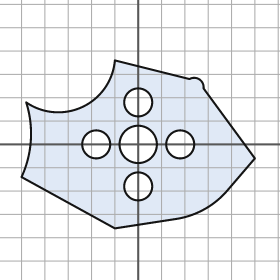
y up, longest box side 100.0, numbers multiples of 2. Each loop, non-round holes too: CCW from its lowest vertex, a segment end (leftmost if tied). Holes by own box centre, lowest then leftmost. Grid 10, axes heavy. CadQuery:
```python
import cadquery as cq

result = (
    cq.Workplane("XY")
    .moveTo(-10.0, -36.0)
    .lineTo(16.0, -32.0)
    .threePointArc((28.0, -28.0), (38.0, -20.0))
    .lineTo(50.0, -6.0)
    .lineTo(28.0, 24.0)
    .threePointArc((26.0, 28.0), (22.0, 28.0))
    .lineTo(-10.0, 36.0)
    .threePointArc((-24.0, 16.0), (-48.0, 18.0))
    .threePointArc((-46.0, 2.0), (-50.0, -14.0))
    .close()
    .moveTo(0.0, -18.0)
    .circle(6.0)
    .moveTo(-18.0, 0.0)
    .circle(6.0)
    .moveTo(0.0, 0.0)
    .circle(8.0)
    .moveTo(18.0, 0.0)
    .circle(6.0)
    .moveTo(0.0, 18.0)
    .circle(6.0)
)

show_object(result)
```